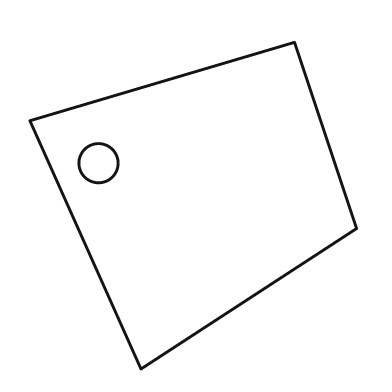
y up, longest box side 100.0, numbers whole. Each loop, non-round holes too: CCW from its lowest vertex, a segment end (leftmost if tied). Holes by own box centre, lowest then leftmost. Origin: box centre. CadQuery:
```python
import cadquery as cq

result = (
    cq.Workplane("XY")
    .moveTo(-16.0, -50.0)
    .lineTo(50.0, -7.0)
    .lineTo(31.0, 50.0)
    .lineTo(-50.0, 26.0)
    .close()
    .moveTo(-29.0, 13.0)
    .circle(6.0)
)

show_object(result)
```